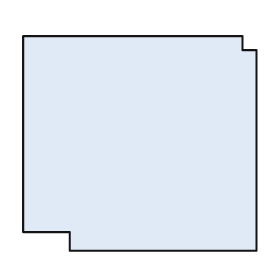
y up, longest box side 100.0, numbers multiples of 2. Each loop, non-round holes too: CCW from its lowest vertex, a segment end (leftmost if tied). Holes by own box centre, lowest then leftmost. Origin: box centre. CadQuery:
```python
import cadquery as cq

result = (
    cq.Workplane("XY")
    .moveTo(-30.0, -46.0)
    .lineTo(50.0, -46.0)
    .lineTo(50.0, 40.0)
    .lineTo(44.0, 40.0)
    .lineTo(44.0, 46.0)
    .lineTo(-50.0, 46.0)
    .lineTo(-50.0, -38.0)
    .lineTo(-30.0, -38.0)
    .close()
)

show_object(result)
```